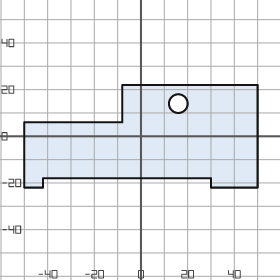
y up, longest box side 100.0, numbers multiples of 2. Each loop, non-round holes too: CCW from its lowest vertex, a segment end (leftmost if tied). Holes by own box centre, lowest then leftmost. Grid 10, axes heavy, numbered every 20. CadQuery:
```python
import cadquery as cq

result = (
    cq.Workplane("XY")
    .moveTo(-50.0, -22.0)
    .lineTo(-42.0, -22.0)
    .lineTo(-42.0, -18.0)
    .lineTo(30.0, -18.0)
    .lineTo(30.0, -22.0)
    .lineTo(50.0, -22.0)
    .lineTo(50.0, 22.0)
    .lineTo(-8.0, 22.0)
    .lineTo(-8.0, 6.0)
    .lineTo(-50.0, 6.0)
    .close()
    .moveTo(16.0, 14.0)
    .circle(4.0)
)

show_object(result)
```